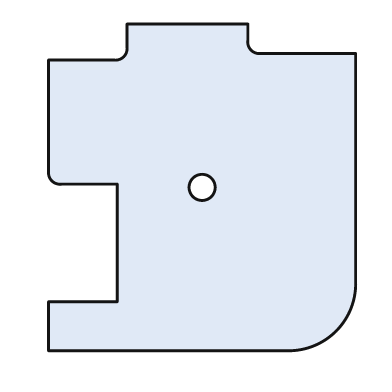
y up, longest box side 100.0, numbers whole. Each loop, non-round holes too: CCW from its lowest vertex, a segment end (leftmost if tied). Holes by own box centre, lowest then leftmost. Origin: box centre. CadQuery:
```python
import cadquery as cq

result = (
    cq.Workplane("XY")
    .moveTo(-47.0, -50.0)
    .lineTo(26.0, -50.0)
    .threePointArc((41.0, -44.0), (47.0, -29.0))
    .lineTo(47.0, 41.0)
    .lineTo(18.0, 41.0)
    .threePointArc((15.0, 42.0), (14.0, 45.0))
    .lineTo(14.0, 50.0)
    .lineTo(-23.0, 50.0)
    .lineTo(-23.0, 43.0)
    .threePointArc((-24.0, 40.0), (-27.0, 39.0))
    .lineTo(-47.0, 39.0)
    .lineTo(-47.0, 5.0)
    .threePointArc((-46.0, 2.0), (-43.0, 1.0))
    .lineTo(-26.0, 1.0)
    .lineTo(-26.0, -35.0)
    .lineTo(-47.0, -35.0)
    .close()
    .moveTo(0.0, 0.0)
    .circle(4.0)
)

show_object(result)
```